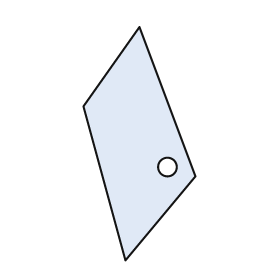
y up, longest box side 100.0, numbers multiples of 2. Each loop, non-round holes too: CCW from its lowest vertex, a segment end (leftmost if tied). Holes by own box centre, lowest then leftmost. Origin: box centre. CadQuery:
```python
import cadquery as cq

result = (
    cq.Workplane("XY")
    .moveTo(-6.0, -50.0)
    .lineTo(24.0, -14.0)
    .lineTo(0.0, 50.0)
    .lineTo(-24.0, 16.0)
    .close()
    .moveTo(12.0, -10.0)
    .circle(4.0)
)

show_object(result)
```